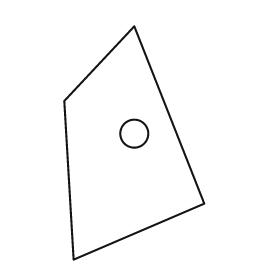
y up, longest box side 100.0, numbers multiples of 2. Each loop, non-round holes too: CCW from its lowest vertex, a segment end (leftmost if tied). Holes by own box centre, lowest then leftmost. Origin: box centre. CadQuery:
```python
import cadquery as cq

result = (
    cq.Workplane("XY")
    .moveTo(-26.0, -50.0)
    .lineTo(30.0, -26.0)
    .lineTo(0.0, 50.0)
    .lineTo(-30.0, 18.0)
    .close()
    .moveTo(0.0, 4.0)
    .circle(6.0)
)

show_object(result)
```